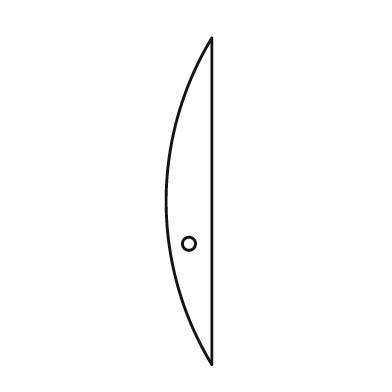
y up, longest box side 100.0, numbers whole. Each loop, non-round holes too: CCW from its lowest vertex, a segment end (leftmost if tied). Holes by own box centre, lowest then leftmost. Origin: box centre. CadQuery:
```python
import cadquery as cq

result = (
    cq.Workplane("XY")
    .moveTo(7.0, -50.0)
    .lineTo(7.0, 50.0)
    .threePointArc((-7.0, 0.0), (7.0, -50.0))
    .close()
    .moveTo(0.0, -13.0)
    .circle(2.0)
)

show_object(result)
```